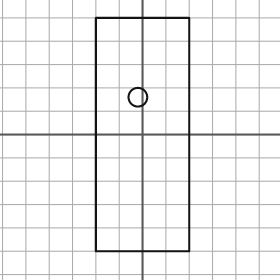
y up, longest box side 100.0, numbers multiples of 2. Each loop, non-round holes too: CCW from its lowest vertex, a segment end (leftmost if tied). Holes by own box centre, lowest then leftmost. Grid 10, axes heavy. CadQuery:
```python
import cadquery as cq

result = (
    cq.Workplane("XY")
    .moveTo(-20.0, -50.0)
    .lineTo(20.0, -50.0)
    .lineTo(20.0, 50.0)
    .lineTo(-20.0, 50.0)
    .close()
    .moveTo(-2.0, 16.0)
    .circle(4.0)
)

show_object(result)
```